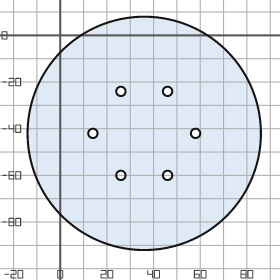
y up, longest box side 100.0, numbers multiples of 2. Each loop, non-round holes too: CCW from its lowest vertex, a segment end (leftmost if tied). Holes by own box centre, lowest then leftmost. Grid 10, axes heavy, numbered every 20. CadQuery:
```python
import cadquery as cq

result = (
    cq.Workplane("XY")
    .moveTo(36.0, -42.0)
    .circle(50.0)
    .moveTo(26.0, -60.0)
    .circle(2.0)
    .moveTo(46.0, -60.0)
    .circle(2.0)
    .moveTo(14.0, -42.0)
    .circle(2.0)
    .moveTo(58.0, -42.0)
    .circle(2.0)
    .moveTo(26.0, -24.0)
    .circle(2.0)
    .moveTo(46.0, -24.0)
    .circle(2.0)
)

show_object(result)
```